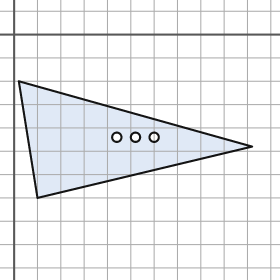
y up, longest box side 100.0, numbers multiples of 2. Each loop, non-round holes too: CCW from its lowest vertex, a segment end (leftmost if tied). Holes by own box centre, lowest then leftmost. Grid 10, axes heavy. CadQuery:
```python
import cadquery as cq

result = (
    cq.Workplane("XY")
    .moveTo(10.0, -70.0)
    .lineTo(102.0, -48.0)
    .lineTo(2.0, -20.0)
    .close()
    .moveTo(44.0, -44.0)
    .circle(2.0)
    .moveTo(52.0, -44.0)
    .circle(2.0)
    .moveTo(60.0, -44.0)
    .circle(2.0)
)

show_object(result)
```